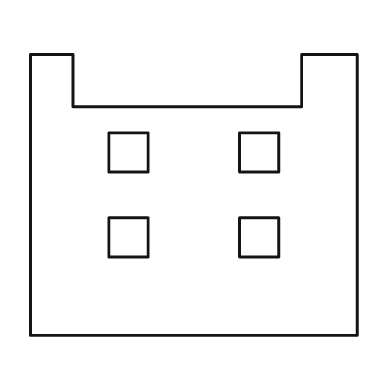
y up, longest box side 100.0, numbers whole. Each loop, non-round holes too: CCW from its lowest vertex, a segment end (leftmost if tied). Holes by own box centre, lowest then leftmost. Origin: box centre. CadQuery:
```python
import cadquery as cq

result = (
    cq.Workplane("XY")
    .moveTo(-50.0, -43.0)
    .lineTo(50.0, -43.0)
    .lineTo(50.0, 43.0)
    .lineTo(33.0, 43.0)
    .lineTo(33.0, 27.0)
    .lineTo(-37.0, 27.0)
    .lineTo(-37.0, 43.0)
    .lineTo(-50.0, 43.0)
    .close()
    .moveTo(-26.0, -19.0)
    .lineTo(-14.0, -19.0)
    .lineTo(-14.0, -7.0)
    .lineTo(-26.0, -7.0)
    .close()
    .moveTo(14.0, -19.0)
    .lineTo(26.0, -19.0)
    .lineTo(26.0, -7.0)
    .lineTo(14.0, -7.0)
    .close()
    .moveTo(-26.0, 7.0)
    .lineTo(-14.0, 7.0)
    .lineTo(-14.0, 19.0)
    .lineTo(-26.0, 19.0)
    .close()
    .moveTo(14.0, 7.0)
    .lineTo(26.0, 7.0)
    .lineTo(26.0, 19.0)
    .lineTo(14.0, 19.0)
    .close()
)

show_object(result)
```